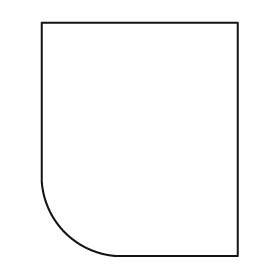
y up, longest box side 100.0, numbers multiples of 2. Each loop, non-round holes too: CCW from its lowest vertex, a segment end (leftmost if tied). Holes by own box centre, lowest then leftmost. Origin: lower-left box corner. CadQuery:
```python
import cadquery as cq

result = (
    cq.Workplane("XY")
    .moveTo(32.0, 0.0)
    .lineTo(84.0, 0.0)
    .lineTo(84.0, 100.0)
    .lineTo(0.0, 100.0)
    .lineTo(0.0, 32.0)
    .threePointArc((10.0, 10.0), (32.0, 0.0))
    .close()
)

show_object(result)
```